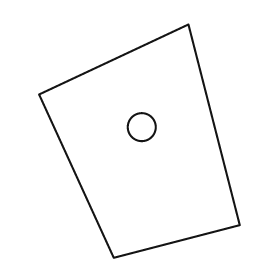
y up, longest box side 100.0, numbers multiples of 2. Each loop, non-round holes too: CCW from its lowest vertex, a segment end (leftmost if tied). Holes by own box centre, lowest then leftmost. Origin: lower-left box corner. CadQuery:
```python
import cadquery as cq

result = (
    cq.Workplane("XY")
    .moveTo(32.0, 0.0)
    .lineTo(86.0, 14.0)
    .lineTo(64.0, 100.0)
    .lineTo(0.0, 70.0)
    .close()
    .moveTo(44.0, 56.0)
    .circle(6.0)
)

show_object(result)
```